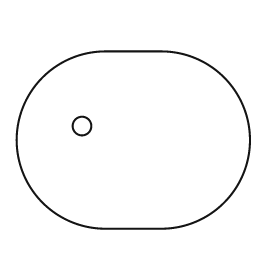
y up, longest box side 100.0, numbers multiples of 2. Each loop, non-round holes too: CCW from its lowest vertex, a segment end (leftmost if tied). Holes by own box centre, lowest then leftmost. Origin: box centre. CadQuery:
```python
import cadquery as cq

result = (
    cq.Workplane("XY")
    .moveTo(-12.0, -38.0)
    .lineTo(12.0, -38.0)
    .threePointArc((50.0, 0.0), (12.0, 38.0))
    .lineTo(-12.0, 38.0)
    .threePointArc((-50.0, 0.0), (-12.0, -38.0))
    .close()
    .moveTo(-22.0, 6.0)
    .circle(4.0)
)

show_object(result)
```